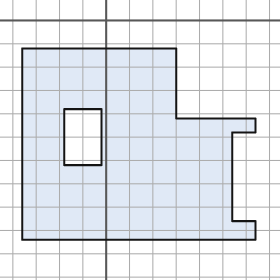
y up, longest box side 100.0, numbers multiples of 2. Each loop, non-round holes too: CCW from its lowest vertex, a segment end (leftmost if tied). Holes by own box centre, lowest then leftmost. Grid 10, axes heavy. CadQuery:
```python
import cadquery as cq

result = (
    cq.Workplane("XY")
    .moveTo(-36.0, -94.0)
    .lineTo(64.0, -94.0)
    .lineTo(64.0, -86.0)
    .lineTo(54.0, -86.0)
    .lineTo(54.0, -48.0)
    .lineTo(64.0, -48.0)
    .lineTo(64.0, -42.0)
    .lineTo(30.0, -42.0)
    .lineTo(30.0, -12.0)
    .lineTo(-36.0, -12.0)
    .close()
    .moveTo(-18.0, -62.0)
    .lineTo(-2.0, -62.0)
    .lineTo(-2.0, -38.0)
    .lineTo(-18.0, -38.0)
    .close()
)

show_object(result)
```